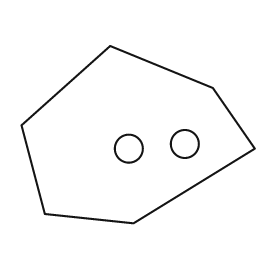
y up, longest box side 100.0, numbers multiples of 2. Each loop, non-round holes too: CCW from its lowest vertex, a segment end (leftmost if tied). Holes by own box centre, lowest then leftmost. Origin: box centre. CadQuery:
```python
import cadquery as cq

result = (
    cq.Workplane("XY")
    .moveTo(-2.0, -38.0)
    .lineTo(50.0, -6.0)
    .lineTo(32.0, 20.0)
    .lineTo(-12.0, 38.0)
    .lineTo(-50.0, 4.0)
    .lineTo(-40.0, -34.0)
    .close()
    .moveTo(-4.0, -6.0)
    .circle(6.0)
    .moveTo(20.0, -4.0)
    .circle(6.0)
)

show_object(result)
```